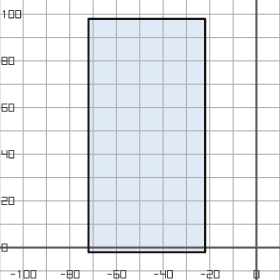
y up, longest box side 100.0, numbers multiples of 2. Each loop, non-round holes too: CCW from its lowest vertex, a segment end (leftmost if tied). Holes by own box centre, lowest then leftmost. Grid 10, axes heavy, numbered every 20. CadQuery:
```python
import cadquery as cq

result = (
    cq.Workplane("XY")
    .moveTo(-72.0, -2.0)
    .lineTo(-22.0, -2.0)
    .lineTo(-22.0, 98.0)
    .lineTo(-72.0, 98.0)
    .close()
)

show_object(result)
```